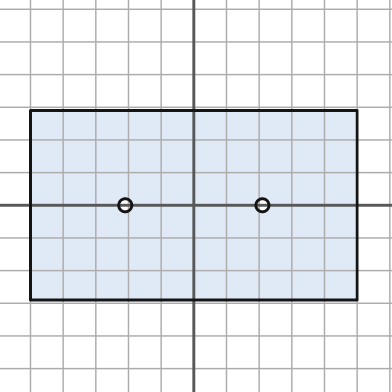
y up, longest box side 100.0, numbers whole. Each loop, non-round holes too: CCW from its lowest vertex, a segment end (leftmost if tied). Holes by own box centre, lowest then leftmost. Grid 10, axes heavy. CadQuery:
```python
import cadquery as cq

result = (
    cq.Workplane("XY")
    .moveTo(-50.0, -29.0)
    .lineTo(50.0, -29.0)
    .lineTo(50.0, 29.0)
    .lineTo(-50.0, 29.0)
    .close()
    .moveTo(-21.0, 0.0)
    .circle(2.0)
    .moveTo(21.0, 0.0)
    .circle(2.0)
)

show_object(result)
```